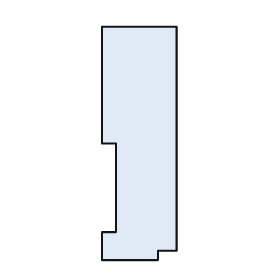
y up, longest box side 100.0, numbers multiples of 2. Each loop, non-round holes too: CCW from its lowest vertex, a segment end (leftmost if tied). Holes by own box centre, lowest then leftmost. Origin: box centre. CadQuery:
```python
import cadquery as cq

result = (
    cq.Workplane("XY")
    .moveTo(-16.0, -50.0)
    .lineTo(8.0, -50.0)
    .lineTo(8.0, -46.0)
    .lineTo(16.0, -46.0)
    .lineTo(16.0, 50.0)
    .lineTo(-16.0, 50.0)
    .lineTo(-16.0, 0.0)
    .lineTo(-10.0, 0.0)
    .lineTo(-10.0, -38.0)
    .lineTo(-16.0, -38.0)
    .close()
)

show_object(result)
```